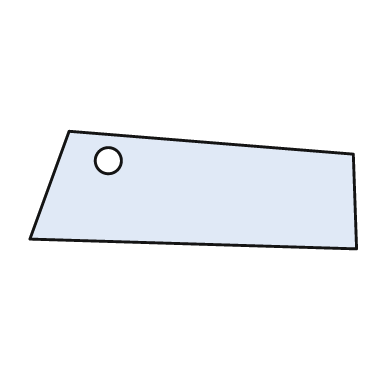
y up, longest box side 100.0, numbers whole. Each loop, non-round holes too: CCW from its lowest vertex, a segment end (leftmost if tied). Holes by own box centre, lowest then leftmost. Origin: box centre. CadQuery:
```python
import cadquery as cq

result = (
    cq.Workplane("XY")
    .moveTo(50.0, -18.0)
    .lineTo(49.0, 11.0)
    .lineTo(-38.0, 18.0)
    .lineTo(-50.0, -15.0)
    .close()
    .moveTo(-26.0, 9.0)
    .circle(4.0)
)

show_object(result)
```